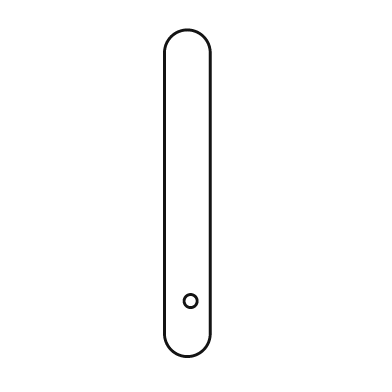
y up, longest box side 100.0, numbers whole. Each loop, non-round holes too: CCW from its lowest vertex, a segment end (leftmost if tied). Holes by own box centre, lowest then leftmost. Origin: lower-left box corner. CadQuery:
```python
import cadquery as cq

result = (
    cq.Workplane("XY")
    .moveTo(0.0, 7.0)
    .threePointArc((7.0, 0.0), (14.0, 7.0))
    .lineTo(14.0, 93.0)
    .threePointArc((7.0, 100.0), (0.0, 93.0))
    .close()
    .moveTo(8.0, 17.0)
    .circle(2.0)
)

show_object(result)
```